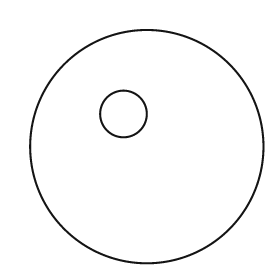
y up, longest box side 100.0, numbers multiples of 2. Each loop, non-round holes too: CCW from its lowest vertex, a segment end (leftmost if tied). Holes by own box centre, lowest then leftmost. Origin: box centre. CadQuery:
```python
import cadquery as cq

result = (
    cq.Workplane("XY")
    .moveTo(0.0, 0.0)
    .circle(50.0)
    .moveTo(-10.0, 14.0)
    .circle(10.0)
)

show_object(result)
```